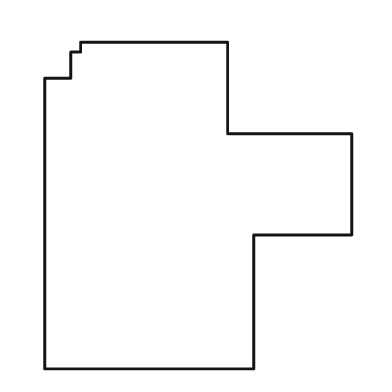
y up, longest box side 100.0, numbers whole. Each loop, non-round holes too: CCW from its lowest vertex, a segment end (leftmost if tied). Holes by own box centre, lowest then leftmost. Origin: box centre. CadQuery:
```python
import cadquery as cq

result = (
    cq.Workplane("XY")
    .moveTo(-47.0, -50.0)
    .lineTo(17.0, -50.0)
    .lineTo(17.0, -9.0)
    .lineTo(47.0, -9.0)
    .lineTo(47.0, 22.0)
    .lineTo(9.0, 22.0)
    .lineTo(9.0, 50.0)
    .lineTo(-36.0, 50.0)
    .lineTo(-36.0, 47.0)
    .lineTo(-39.0, 47.0)
    .lineTo(-39.0, 39.0)
    .lineTo(-47.0, 39.0)
    .close()
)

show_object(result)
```